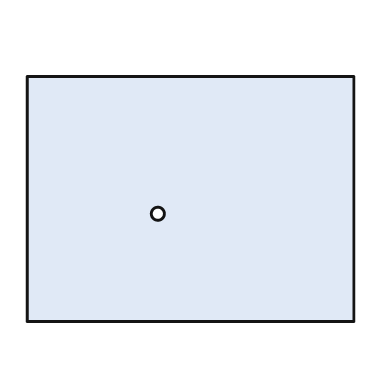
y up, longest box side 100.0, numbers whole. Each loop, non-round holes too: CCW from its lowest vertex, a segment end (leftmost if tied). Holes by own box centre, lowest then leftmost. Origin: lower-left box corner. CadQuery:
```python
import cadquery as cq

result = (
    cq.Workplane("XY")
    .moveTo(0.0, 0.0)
    .lineTo(100.0, 0.0)
    .lineTo(100.0, 75.0)
    .lineTo(0.0, 75.0)
    .close()
    .moveTo(40.0, 33.0)
    .circle(2.0)
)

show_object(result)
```